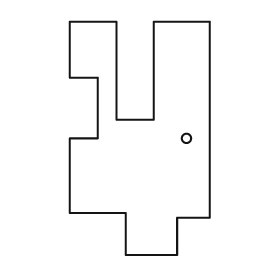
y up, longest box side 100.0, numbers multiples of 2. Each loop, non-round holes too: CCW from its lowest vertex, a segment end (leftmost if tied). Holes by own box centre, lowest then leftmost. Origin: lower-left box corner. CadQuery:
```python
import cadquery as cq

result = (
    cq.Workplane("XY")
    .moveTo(24.0, 0.0)
    .lineTo(46.0, 0.0)
    .lineTo(46.0, 16.0)
    .lineTo(60.0, 16.0)
    .lineTo(60.0, 100.0)
    .lineTo(36.0, 100.0)
    .lineTo(36.0, 58.0)
    .lineTo(20.0, 58.0)
    .lineTo(20.0, 100.0)
    .lineTo(0.0, 100.0)
    .lineTo(0.0, 76.0)
    .lineTo(12.0, 76.0)
    .lineTo(12.0, 50.0)
    .lineTo(0.0, 50.0)
    .lineTo(0.0, 18.0)
    .lineTo(24.0, 18.0)
    .close()
    .moveTo(50.0, 50.0)
    .circle(2.0)
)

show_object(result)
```